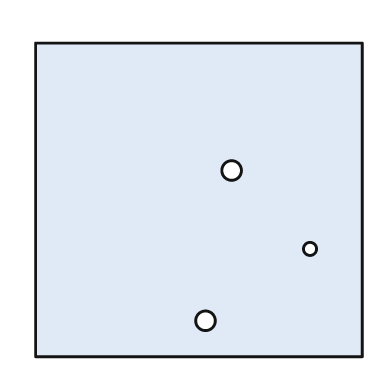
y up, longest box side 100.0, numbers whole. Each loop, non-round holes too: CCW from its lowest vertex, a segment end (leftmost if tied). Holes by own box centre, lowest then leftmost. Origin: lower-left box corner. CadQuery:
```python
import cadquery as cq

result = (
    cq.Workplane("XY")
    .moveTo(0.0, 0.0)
    .lineTo(100.0, 0.0)
    .lineTo(100.0, 96.0)
    .lineTo(0.0, 96.0)
    .close()
    .moveTo(52.0, 11.0)
    .circle(3.0)
    .moveTo(84.0, 33.0)
    .circle(2.0)
    .moveTo(60.0, 57.0)
    .circle(3.0)
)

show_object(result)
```